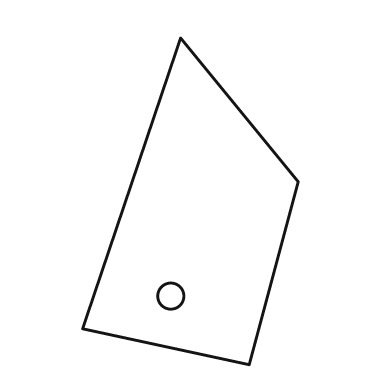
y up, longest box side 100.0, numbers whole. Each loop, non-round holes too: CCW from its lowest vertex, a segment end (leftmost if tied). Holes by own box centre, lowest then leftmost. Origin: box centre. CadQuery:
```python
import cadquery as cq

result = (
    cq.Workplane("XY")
    .moveTo(18.0, -50.0)
    .lineTo(33.0, 6.0)
    .lineTo(-3.0, 50.0)
    .lineTo(-33.0, -39.0)
    .close()
    .moveTo(-6.0, -29.0)
    .circle(4.0)
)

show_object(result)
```